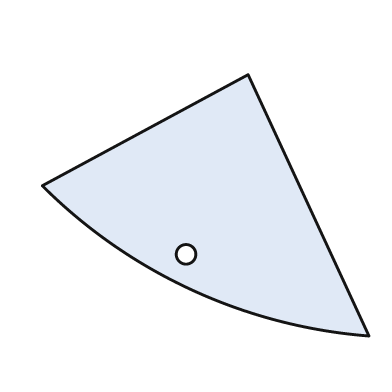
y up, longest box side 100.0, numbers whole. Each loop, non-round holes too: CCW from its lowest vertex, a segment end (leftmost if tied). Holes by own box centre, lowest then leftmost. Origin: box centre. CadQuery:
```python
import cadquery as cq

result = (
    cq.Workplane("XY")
    .moveTo(50.0, -40.0)
    .lineTo(13.0, 40.0)
    .lineTo(-50.0, 6.0)
    .threePointArc((-4.0, -26.0), (50.0, -40.0))
    .close()
    .moveTo(-6.0, -15.0)
    .circle(3.0)
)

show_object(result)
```